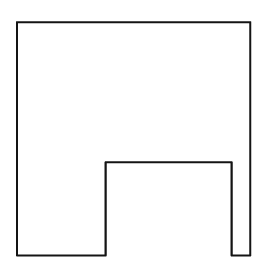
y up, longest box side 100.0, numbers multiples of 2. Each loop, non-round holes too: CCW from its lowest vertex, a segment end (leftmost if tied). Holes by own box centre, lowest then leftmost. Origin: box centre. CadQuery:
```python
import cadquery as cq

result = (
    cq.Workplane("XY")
    .moveTo(-50.0, -50.0)
    .lineTo(-12.0, -50.0)
    .lineTo(-12.0, -10.0)
    .lineTo(42.0, -10.0)
    .lineTo(42.0, -50.0)
    .lineTo(50.0, -50.0)
    .lineTo(50.0, 50.0)
    .lineTo(-50.0, 50.0)
    .close()
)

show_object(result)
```